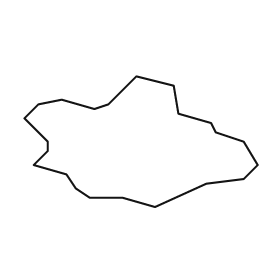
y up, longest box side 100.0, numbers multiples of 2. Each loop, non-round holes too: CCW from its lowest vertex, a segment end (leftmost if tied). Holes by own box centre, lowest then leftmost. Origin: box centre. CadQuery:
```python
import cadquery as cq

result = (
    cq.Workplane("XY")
    .moveTo(6.0, -28.0)
    .lineTo(28.0, -18.0)
    .lineTo(44.0, -16.0)
    .lineTo(50.0, -10.0)
    .lineTo(44.0, 0.0)
    .lineTo(32.0, 4.0)
    .lineTo(30.0, 8.0)
    .lineTo(16.0, 12.0)
    .lineTo(14.0, 24.0)
    .lineTo(-2.0, 28.0)
    .lineTo(-14.0, 16.0)
    .lineTo(-20.0, 14.0)
    .lineTo(-34.0, 18.0)
    .lineTo(-44.0, 16.0)
    .lineTo(-50.0, 10.0)
    .lineTo(-40.0, 0.0)
    .lineTo(-40.0, -4.0)
    .lineTo(-46.0, -10.0)
    .lineTo(-32.0, -14.0)
    .lineTo(-28.0, -20.0)
    .lineTo(-22.0, -24.0)
    .lineTo(-8.0, -24.0)
    .close()
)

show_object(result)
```